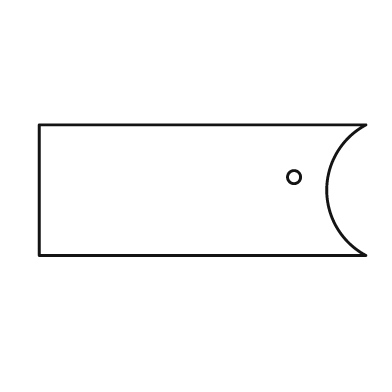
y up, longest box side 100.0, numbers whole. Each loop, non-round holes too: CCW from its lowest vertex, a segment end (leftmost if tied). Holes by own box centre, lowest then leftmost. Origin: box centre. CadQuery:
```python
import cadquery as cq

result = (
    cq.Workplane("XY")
    .moveTo(-50.0, -20.0)
    .lineTo(50.0, -20.0)
    .threePointArc((38.0, 0.0), (50.0, 20.0))
    .lineTo(-50.0, 20.0)
    .close()
    .moveTo(28.0, 4.0)
    .circle(2.0)
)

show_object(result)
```